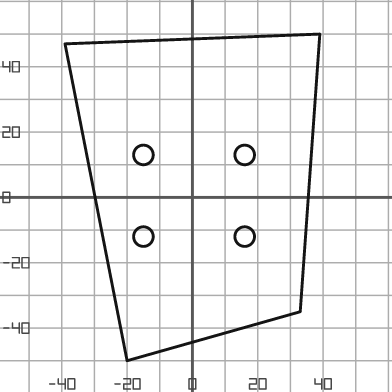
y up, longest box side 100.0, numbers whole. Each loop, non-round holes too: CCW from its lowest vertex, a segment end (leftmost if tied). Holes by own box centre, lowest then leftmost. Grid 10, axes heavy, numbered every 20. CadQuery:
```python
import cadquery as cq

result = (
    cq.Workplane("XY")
    .moveTo(-20.0, -50.0)
    .lineTo(33.0, -35.0)
    .lineTo(39.0, 50.0)
    .lineTo(-39.0, 47.0)
    .close()
    .moveTo(-15.0, -12.0)
    .circle(3.0)
    .moveTo(16.0, -12.0)
    .circle(3.0)
    .moveTo(-15.0, 13.0)
    .circle(3.0)
    .moveTo(16.0, 13.0)
    .circle(3.0)
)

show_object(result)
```